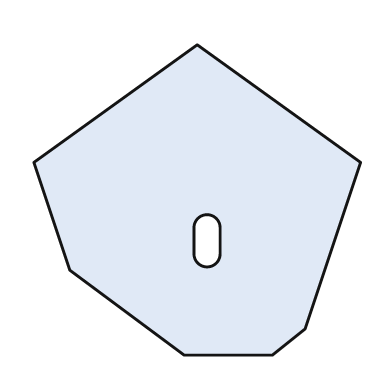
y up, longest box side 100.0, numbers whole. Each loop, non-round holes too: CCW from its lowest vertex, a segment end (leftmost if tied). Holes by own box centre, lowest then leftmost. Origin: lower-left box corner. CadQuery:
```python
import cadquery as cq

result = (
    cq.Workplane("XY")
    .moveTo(46.0, 0.0)
    .lineTo(73.0, 0.0)
    .lineTo(83.0, 8.0)
    .lineTo(100.0, 59.0)
    .lineTo(50.0, 95.0)
    .lineTo(0.0, 59.0)
    .lineTo(11.0, 26.0)
    .close()
    .moveTo(49.0, 31.0)
    .threePointArc((53.0, 27.0), (57.0, 31.0))
    .lineTo(57.0, 39.0)
    .threePointArc((53.0, 43.0), (49.0, 39.0))
    .close()
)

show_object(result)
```